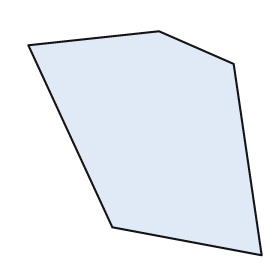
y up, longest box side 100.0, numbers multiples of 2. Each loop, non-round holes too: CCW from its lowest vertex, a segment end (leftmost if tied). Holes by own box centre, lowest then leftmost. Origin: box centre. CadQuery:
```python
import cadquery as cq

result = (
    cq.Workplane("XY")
    .moveTo(50.0, -48.0)
    .lineTo(38.0, 34.0)
    .lineTo(6.0, 48.0)
    .lineTo(-50.0, 42.0)
    .lineTo(-14.0, -36.0)
    .close()
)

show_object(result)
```